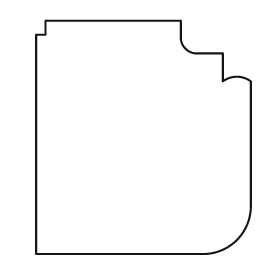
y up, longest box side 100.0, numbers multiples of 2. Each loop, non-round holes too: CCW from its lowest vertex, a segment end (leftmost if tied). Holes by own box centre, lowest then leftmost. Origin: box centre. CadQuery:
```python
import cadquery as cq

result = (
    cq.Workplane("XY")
    .moveTo(-46.0, -50.0)
    .lineTo(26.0, -50.0)
    .threePointArc((40.0, -44.0), (46.0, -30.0))
    .lineTo(46.0, 24.0)
    .threePointArc((40.0, 26.0), (34.0, 24.0))
    .lineTo(34.0, 36.0)
    .lineTo(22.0, 36.0)
    .threePointArc((18.0, 38.0), (16.0, 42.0))
    .lineTo(16.0, 50.0)
    .lineTo(-42.0, 50.0)
    .lineTo(-42.0, 44.0)
    .lineTo(-46.0, 44.0)
    .close()
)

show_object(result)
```